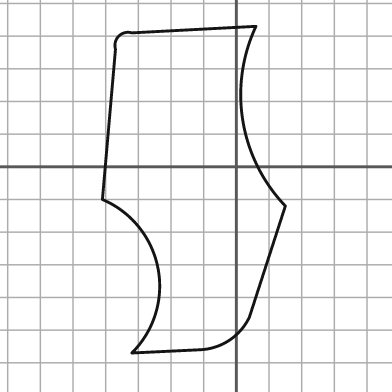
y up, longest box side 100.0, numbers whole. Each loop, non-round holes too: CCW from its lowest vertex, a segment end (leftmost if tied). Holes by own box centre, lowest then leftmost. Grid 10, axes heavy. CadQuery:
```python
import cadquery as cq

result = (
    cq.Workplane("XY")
    .moveTo(-32.0, -57.0)
    .lineTo(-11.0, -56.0)
    .threePointArc((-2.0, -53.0), (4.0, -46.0))
    .lineTo(15.0, -12.0)
    .threePointArc((2.0, 14.0), (6.0, 43.0))
    .lineTo(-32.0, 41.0)
    .threePointArc((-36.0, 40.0), (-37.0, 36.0))
    .lineTo(-41.0, -10.0)
    .threePointArc((-24.0, -31.0), (-32.0, -57.0))
    .close()
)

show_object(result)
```